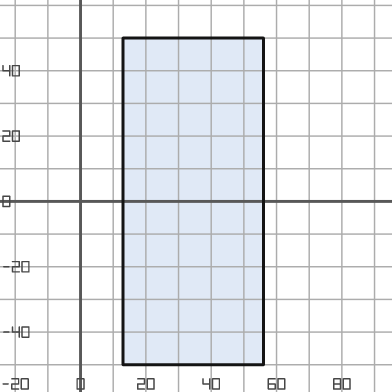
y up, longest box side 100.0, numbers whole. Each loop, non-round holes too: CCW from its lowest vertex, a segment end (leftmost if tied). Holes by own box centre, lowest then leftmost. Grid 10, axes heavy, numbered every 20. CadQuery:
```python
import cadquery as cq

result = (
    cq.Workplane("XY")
    .moveTo(13.0, -50.0)
    .lineTo(56.0, -50.0)
    .lineTo(56.0, 50.0)
    .lineTo(13.0, 50.0)
    .close()
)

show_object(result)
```